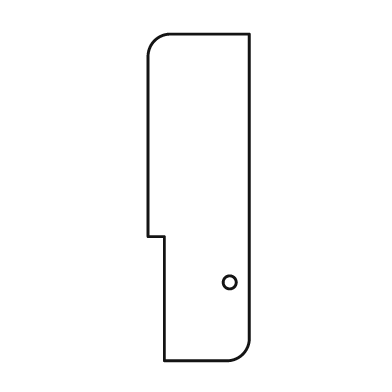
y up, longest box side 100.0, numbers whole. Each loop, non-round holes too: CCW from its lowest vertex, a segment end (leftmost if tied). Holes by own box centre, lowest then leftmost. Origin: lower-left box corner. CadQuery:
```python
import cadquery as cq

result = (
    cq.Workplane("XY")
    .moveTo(5.0, 0.0)
    .lineTo(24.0, 0.0)
    .threePointArc((29.0, 2.0), (31.0, 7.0))
    .lineTo(31.0, 100.0)
    .lineTo(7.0, 100.0)
    .threePointArc((2.0, 98.0), (0.0, 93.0))
    .lineTo(0.0, 38.0)
    .lineTo(5.0, 38.0)
    .close()
    .moveTo(25.0, 24.0)
    .circle(2.0)
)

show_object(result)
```